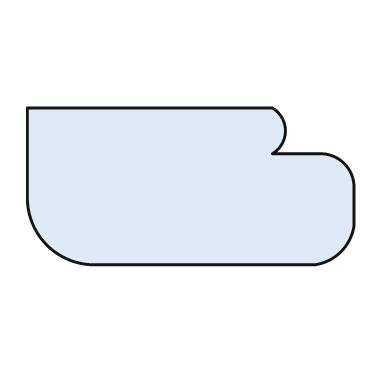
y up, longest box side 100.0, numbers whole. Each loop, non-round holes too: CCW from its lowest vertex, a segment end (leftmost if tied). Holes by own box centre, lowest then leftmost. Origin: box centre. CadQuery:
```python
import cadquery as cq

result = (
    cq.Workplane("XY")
    .moveTo(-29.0, -24.0)
    .lineTo(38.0, -24.0)
    .threePointArc((46.0, -20.0), (50.0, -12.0))
    .lineTo(50.0, 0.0)
    .threePointArc((47.0, 7.0), (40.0, 10.0))
    .lineTo(25.0, 10.0)
    .threePointArc((29.0, 17.0), (25.0, 24.0))
    .lineTo(-50.0, 24.0)
    .lineTo(-50.0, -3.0)
    .threePointArc((-44.0, -18.0), (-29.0, -24.0))
    .close()
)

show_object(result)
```